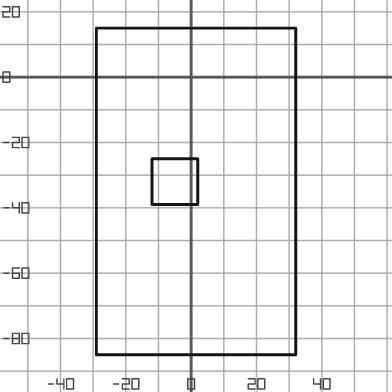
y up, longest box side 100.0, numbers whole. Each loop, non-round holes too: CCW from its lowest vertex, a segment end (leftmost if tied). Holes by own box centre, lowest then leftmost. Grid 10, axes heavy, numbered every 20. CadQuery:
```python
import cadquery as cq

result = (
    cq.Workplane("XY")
    .moveTo(-29.0, -85.0)
    .lineTo(32.0, -85.0)
    .lineTo(32.0, 15.0)
    .lineTo(-29.0, 15.0)
    .close()
    .moveTo(-12.0, -39.0)
    .lineTo(2.0, -39.0)
    .lineTo(2.0, -25.0)
    .lineTo(-12.0, -25.0)
    .close()
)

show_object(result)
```